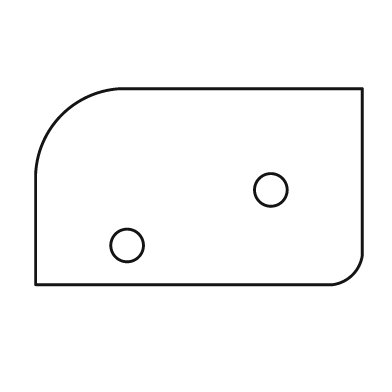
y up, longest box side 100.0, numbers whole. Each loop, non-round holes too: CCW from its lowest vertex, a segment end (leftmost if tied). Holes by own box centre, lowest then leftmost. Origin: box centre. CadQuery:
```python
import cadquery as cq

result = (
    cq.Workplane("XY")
    .moveTo(-50.0, -30.0)
    .lineTo(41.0, -30.0)
    .threePointArc((47.0, -27.0), (50.0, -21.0))
    .lineTo(50.0, 30.0)
    .lineTo(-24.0, 30.0)
    .threePointArc((-42.0, 22.0), (-50.0, 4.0))
    .close()
    .moveTo(-22.0, -18.0)
    .circle(5.0)
    .moveTo(22.0, -1.0)
    .circle(5.0)
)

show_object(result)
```